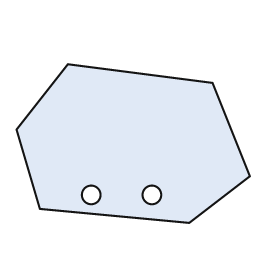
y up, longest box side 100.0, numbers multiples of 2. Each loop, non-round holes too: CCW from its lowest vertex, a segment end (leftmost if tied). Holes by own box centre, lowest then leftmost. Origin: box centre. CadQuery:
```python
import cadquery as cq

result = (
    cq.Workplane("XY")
    .moveTo(24.0, -34.0)
    .lineTo(50.0, -14.0)
    .lineTo(34.0, 26.0)
    .lineTo(-28.0, 34.0)
    .lineTo(-50.0, 6.0)
    .lineTo(-40.0, -28.0)
    .close()
    .moveTo(-18.0, -22.0)
    .circle(4.0)
    .moveTo(8.0, -22.0)
    .circle(4.0)
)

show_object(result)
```